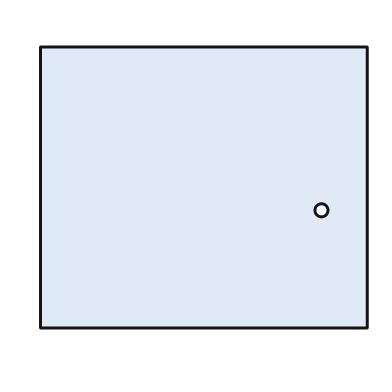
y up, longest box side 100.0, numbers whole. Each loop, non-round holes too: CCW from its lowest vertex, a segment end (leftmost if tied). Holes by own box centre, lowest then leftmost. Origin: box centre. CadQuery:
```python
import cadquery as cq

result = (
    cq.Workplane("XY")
    .moveTo(-50.0, -43.0)
    .lineTo(50.0, -43.0)
    .lineTo(50.0, 43.0)
    .lineTo(-50.0, 43.0)
    .close()
    .moveTo(36.0, -7.0)
    .circle(2.0)
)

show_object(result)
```